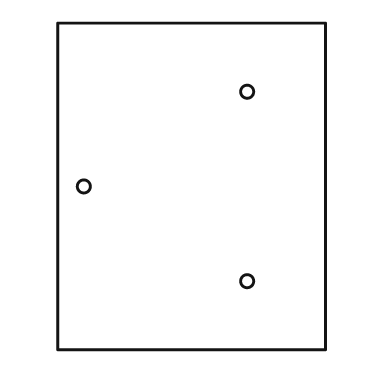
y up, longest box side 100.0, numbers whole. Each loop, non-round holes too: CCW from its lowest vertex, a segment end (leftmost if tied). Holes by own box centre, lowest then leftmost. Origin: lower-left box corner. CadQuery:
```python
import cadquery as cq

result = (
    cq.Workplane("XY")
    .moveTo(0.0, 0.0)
    .lineTo(82.0, 0.0)
    .lineTo(82.0, 100.0)
    .lineTo(0.0, 100.0)
    .close()
    .moveTo(58.0, 21.0)
    .circle(2.0)
    .moveTo(8.0, 50.0)
    .circle(2.0)
    .moveTo(58.0, 79.0)
    .circle(2.0)
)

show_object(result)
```